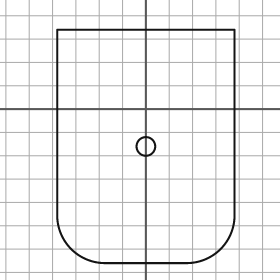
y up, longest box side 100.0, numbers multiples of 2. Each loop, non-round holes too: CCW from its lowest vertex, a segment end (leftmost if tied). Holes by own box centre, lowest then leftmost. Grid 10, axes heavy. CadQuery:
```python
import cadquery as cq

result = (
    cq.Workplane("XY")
    .moveTo(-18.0, -66.0)
    .lineTo(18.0, -66.0)
    .threePointArc((32.0, -60.0), (38.0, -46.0))
    .lineTo(38.0, 34.0)
    .lineTo(-38.0, 34.0)
    .lineTo(-38.0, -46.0)
    .threePointArc((-32.0, -60.0), (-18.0, -66.0))
    .close()
    .moveTo(0.0, -16.0)
    .circle(4.0)
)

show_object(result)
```